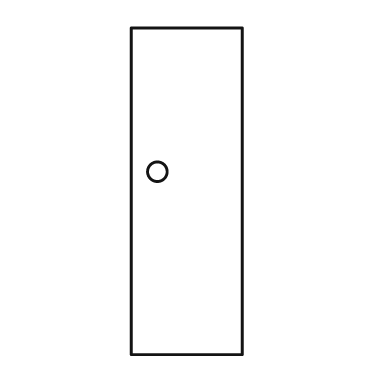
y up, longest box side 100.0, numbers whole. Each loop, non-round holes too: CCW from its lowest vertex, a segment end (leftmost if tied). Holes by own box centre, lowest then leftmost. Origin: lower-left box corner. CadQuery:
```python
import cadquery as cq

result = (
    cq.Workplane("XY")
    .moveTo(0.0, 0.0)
    .lineTo(34.0, 0.0)
    .lineTo(34.0, 100.0)
    .lineTo(0.0, 100.0)
    .close()
    .moveTo(8.0, 56.0)
    .circle(3.0)
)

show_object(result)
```